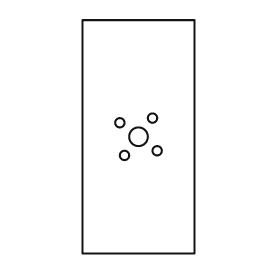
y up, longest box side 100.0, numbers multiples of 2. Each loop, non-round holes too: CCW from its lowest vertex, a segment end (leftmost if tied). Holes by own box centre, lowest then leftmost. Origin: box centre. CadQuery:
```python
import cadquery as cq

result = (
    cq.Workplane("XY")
    .moveTo(-24.0, -50.0)
    .lineTo(24.0, -50.0)
    .lineTo(24.0, 50.0)
    .lineTo(-24.0, 50.0)
    .close()
    .moveTo(-6.0, -8.0)
    .circle(2.0)
    .moveTo(8.0, -6.0)
    .circle(2.0)
    .moveTo(0.0, 0.0)
    .circle(4.0)
    .moveTo(-8.0, 6.0)
    .circle(2.0)
    .moveTo(6.0, 8.0)
    .circle(2.0)
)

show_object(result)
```